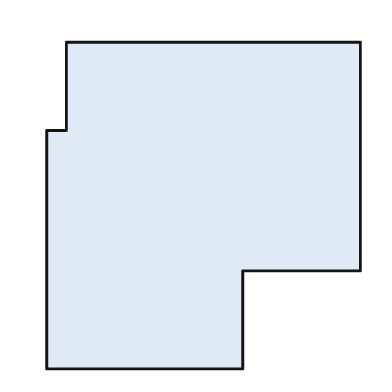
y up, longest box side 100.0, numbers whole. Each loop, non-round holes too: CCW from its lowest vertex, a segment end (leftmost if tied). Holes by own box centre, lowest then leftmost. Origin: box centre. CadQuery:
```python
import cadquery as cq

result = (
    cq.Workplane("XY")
    .moveTo(-48.0, -50.0)
    .lineTo(12.0, -50.0)
    .lineTo(12.0, -20.0)
    .lineTo(48.0, -20.0)
    .lineTo(48.0, 50.0)
    .lineTo(-42.0, 50.0)
    .lineTo(-42.0, 23.0)
    .lineTo(-48.0, 23.0)
    .close()
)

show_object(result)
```